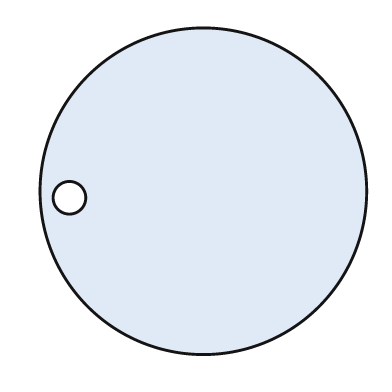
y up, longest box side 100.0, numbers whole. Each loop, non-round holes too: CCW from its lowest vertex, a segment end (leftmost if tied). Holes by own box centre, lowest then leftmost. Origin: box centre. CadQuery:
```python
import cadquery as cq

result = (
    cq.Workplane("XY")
    .moveTo(0.0, 0.0)
    .circle(50.0)
    .moveTo(-41.0, -2.0)
    .circle(5.0)
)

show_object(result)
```